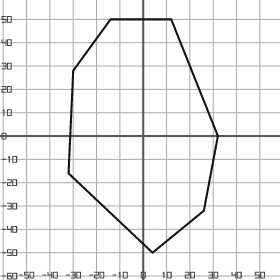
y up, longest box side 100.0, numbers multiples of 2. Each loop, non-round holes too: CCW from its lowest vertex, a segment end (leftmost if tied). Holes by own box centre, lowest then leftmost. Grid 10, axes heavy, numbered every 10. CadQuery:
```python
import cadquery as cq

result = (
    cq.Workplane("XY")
    .moveTo(4.0, -50.0)
    .lineTo(26.0, -32.0)
    .lineTo(32.0, 0.0)
    .lineTo(12.0, 50.0)
    .lineTo(-14.0, 50.0)
    .lineTo(-30.0, 28.0)
    .lineTo(-32.0, -16.0)
    .close()
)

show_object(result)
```